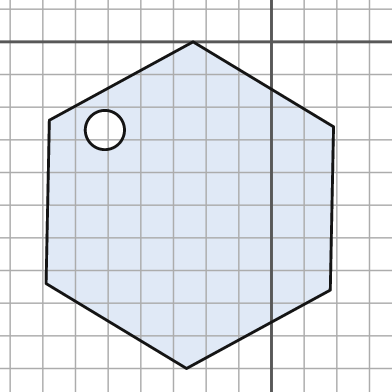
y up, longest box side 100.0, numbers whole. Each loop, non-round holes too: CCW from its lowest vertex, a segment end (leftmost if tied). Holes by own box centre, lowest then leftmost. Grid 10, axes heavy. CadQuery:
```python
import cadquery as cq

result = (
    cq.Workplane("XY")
    .moveTo(-26.0, -100.0)
    .lineTo(18.0, -76.0)
    .lineTo(19.0, -26.0)
    .lineTo(-24.0, 0.0)
    .lineTo(-68.0, -24.0)
    .lineTo(-69.0, -74.0)
    .close()
    .moveTo(-51.0, -27.0)
    .circle(6.0)
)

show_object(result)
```